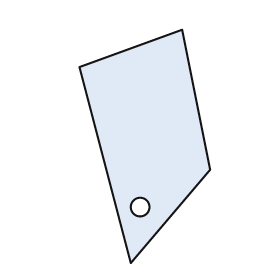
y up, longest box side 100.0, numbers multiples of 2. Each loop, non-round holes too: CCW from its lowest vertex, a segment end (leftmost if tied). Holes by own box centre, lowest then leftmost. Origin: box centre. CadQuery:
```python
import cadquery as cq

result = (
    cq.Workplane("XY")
    .moveTo(-6.0, -50.0)
    .lineTo(28.0, -10.0)
    .lineTo(16.0, 50.0)
    .lineTo(-28.0, 34.0)
    .close()
    .moveTo(-2.0, -26.0)
    .circle(4.0)
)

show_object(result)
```